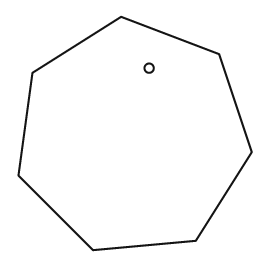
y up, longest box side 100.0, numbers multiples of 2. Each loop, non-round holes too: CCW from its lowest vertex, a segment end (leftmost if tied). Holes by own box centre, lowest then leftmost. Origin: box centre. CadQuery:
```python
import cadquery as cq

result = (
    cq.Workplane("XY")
    .moveTo(-18.0, -50.0)
    .lineTo(26.0, -46.0)
    .lineTo(50.0, -8.0)
    .lineTo(36.0, 34.0)
    .lineTo(-6.0, 50.0)
    .lineTo(-44.0, 26.0)
    .lineTo(-50.0, -18.0)
    .close()
    .moveTo(6.0, 28.0)
    .circle(2.0)
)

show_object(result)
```